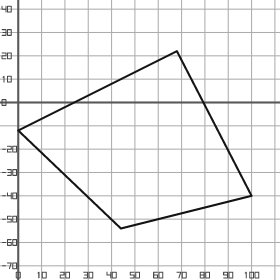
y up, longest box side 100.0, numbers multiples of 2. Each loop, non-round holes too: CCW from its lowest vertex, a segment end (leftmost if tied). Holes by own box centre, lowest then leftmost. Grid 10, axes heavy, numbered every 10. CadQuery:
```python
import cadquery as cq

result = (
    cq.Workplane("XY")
    .moveTo(44.0, -54.0)
    .lineTo(100.0, -40.0)
    .lineTo(68.0, 22.0)
    .lineTo(0.0, -12.0)
    .close()
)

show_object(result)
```